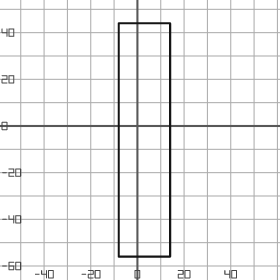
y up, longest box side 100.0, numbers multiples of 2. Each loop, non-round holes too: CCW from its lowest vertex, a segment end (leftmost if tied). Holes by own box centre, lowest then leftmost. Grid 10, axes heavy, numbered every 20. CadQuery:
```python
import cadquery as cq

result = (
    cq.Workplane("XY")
    .moveTo(-8.0, -56.0)
    .lineTo(14.0, -56.0)
    .lineTo(14.0, 44.0)
    .lineTo(-8.0, 44.0)
    .close()
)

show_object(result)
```